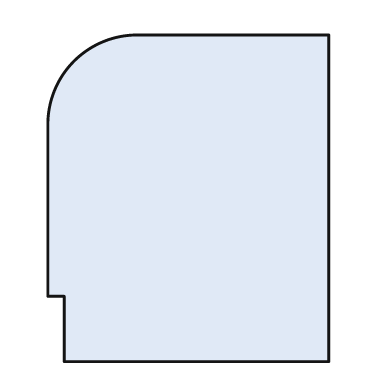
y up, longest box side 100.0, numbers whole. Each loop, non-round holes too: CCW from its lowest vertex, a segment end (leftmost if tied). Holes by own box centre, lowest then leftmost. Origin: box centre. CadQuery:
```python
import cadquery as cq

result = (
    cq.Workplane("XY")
    .moveTo(-38.0, -50.0)
    .lineTo(43.0, -50.0)
    .lineTo(43.0, 50.0)
    .lineTo(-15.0, 50.0)
    .threePointArc((-35.0, 42.0), (-43.0, 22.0))
    .lineTo(-43.0, -30.0)
    .lineTo(-38.0, -30.0)
    .close()
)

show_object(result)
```